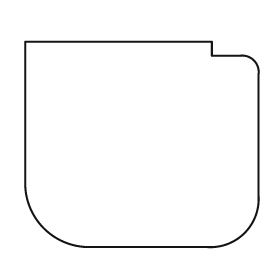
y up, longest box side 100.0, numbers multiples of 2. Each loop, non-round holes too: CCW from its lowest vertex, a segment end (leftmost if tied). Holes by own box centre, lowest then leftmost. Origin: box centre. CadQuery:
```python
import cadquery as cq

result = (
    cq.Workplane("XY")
    .moveTo(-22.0, -44.0)
    .lineTo(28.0, -44.0)
    .threePointArc((44.0, -38.0), (50.0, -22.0))
    .lineTo(50.0, 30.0)
    .threePointArc((48.0, 36.0), (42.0, 38.0))
    .lineTo(30.0, 38.0)
    .lineTo(30.0, 44.0)
    .lineTo(-50.0, 44.0)
    .lineTo(-50.0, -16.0)
    .threePointArc((-42.0, -36.0), (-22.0, -44.0))
    .close()
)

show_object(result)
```